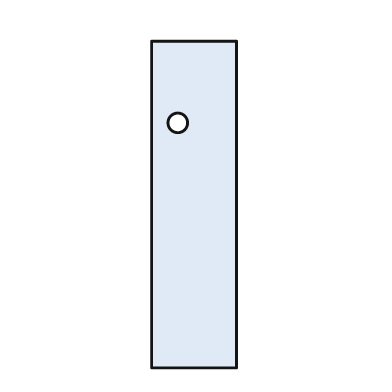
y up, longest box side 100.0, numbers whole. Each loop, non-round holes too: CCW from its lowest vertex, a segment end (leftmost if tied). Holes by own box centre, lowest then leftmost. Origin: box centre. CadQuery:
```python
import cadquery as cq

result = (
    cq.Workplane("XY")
    .moveTo(-13.0, -50.0)
    .lineTo(13.0, -50.0)
    .lineTo(13.0, 50.0)
    .lineTo(-13.0, 50.0)
    .close()
    .moveTo(-5.0, 25.0)
    .circle(3.0)
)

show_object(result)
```